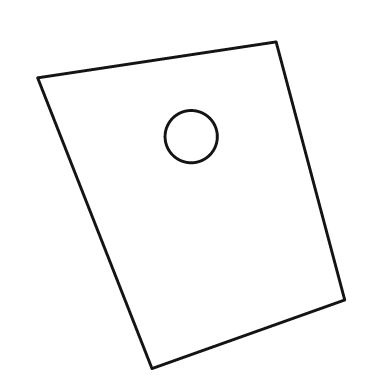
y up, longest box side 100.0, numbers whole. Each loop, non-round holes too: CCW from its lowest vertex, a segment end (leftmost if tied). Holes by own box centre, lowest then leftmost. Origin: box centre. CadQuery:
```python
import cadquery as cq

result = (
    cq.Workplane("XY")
    .moveTo(-12.0, -50.0)
    .lineTo(47.0, -29.0)
    .lineTo(26.0, 50.0)
    .lineTo(-47.0, 39.0)
    .close()
    .moveTo(0.0, 21.0)
    .circle(8.0)
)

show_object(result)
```